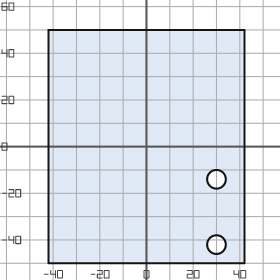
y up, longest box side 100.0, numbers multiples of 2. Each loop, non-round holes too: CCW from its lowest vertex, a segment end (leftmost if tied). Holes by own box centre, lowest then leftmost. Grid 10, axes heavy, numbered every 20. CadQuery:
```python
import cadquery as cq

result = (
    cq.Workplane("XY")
    .moveTo(-42.0, -50.0)
    .lineTo(42.0, -50.0)
    .lineTo(42.0, 50.0)
    .lineTo(-42.0, 50.0)
    .close()
    .moveTo(30.0, -42.0)
    .circle(4.0)
    .moveTo(30.0, -14.0)
    .circle(4.0)
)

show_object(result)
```